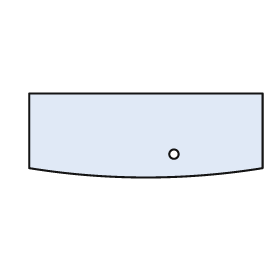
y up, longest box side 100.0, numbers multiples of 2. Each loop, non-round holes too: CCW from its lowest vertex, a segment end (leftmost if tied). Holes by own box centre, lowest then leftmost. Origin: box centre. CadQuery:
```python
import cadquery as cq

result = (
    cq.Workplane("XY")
    .moveTo(-50.0, -14.0)
    .threePointArc((0.0, -18.0), (50.0, -14.0))
    .lineTo(50.0, 18.0)
    .lineTo(-50.0, 18.0)
    .close()
    .moveTo(12.0, -8.0)
    .circle(2.0)
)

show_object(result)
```